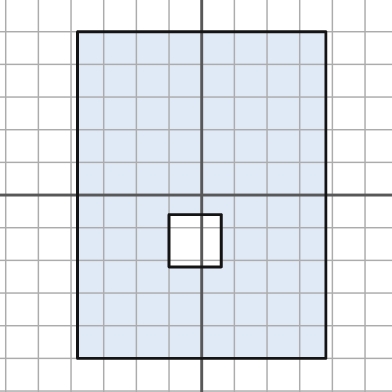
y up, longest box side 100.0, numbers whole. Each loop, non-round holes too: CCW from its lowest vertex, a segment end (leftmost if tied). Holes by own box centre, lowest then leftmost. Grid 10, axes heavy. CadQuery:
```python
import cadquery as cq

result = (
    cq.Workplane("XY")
    .moveTo(-38.0, -50.0)
    .lineTo(38.0, -50.0)
    .lineTo(38.0, 50.0)
    .lineTo(-38.0, 50.0)
    .close()
    .moveTo(-10.0, -22.0)
    .lineTo(6.0, -22.0)
    .lineTo(6.0, -6.0)
    .lineTo(-10.0, -6.0)
    .close()
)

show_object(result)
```